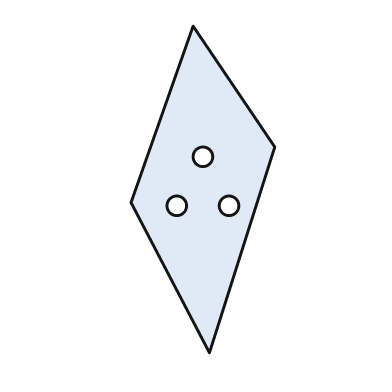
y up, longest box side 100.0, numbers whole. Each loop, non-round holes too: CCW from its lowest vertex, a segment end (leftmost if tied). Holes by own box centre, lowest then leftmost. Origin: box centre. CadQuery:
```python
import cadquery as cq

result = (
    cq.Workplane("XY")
    .moveTo(2.0, -50.0)
    .lineTo(22.0, 13.0)
    .lineTo(-3.0, 50.0)
    .lineTo(-22.0, -4.0)
    .close()
    .moveTo(-8.0, -5.0)
    .circle(3.0)
    .moveTo(8.0, -5.0)
    .circle(3.0)
    .moveTo(0.0, 10.0)
    .circle(3.0)
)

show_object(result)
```